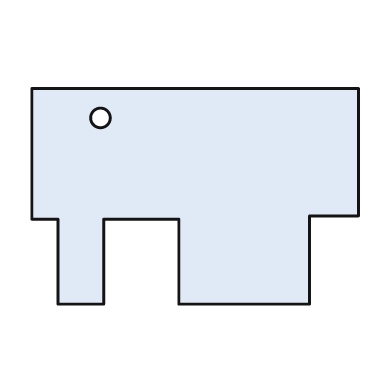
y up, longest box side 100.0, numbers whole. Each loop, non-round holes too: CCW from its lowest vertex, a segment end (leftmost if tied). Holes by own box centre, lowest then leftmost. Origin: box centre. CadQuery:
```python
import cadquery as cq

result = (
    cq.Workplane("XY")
    .moveTo(-42.0, -33.0)
    .lineTo(-28.0, -33.0)
    .lineTo(-28.0, -7.0)
    .lineTo(-5.0, -7.0)
    .lineTo(-5.0, -33.0)
    .lineTo(35.0, -33.0)
    .lineTo(35.0, -6.0)
    .lineTo(50.0, -6.0)
    .lineTo(50.0, 33.0)
    .lineTo(-50.0, 33.0)
    .lineTo(-50.0, -7.0)
    .lineTo(-42.0, -7.0)
    .close()
    .moveTo(-29.0, 24.0)
    .circle(3.0)
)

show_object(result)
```